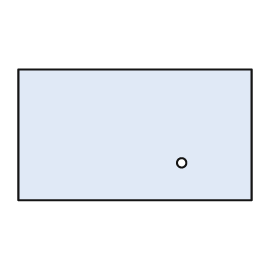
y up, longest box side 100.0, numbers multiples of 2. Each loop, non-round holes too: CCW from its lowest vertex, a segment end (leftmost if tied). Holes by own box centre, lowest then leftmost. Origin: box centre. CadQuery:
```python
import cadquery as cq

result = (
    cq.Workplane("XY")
    .moveTo(-50.0, -28.0)
    .lineTo(50.0, -28.0)
    .lineTo(50.0, 28.0)
    .lineTo(-50.0, 28.0)
    .close()
    .moveTo(20.0, -12.0)
    .circle(2.0)
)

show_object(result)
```